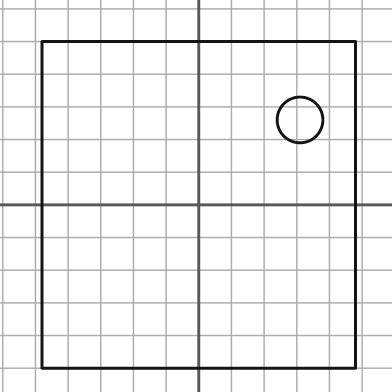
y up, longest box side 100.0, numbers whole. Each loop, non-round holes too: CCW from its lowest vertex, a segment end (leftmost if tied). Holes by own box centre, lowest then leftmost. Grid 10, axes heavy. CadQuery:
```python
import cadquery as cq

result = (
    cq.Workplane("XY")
    .moveTo(-48.0, -50.0)
    .lineTo(48.0, -50.0)
    .lineTo(48.0, 50.0)
    .lineTo(-48.0, 50.0)
    .close()
    .moveTo(31.0, 26.0)
    .circle(7.0)
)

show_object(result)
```